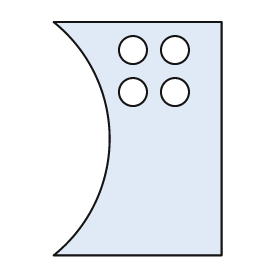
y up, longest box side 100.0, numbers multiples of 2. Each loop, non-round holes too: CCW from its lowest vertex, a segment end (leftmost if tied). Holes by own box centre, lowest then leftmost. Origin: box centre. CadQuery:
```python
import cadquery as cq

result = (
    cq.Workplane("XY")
    .moveTo(-36.0, -50.0)
    .lineTo(36.0, -50.0)
    .lineTo(36.0, 50.0)
    .lineTo(-36.0, 50.0)
    .threePointArc((-12.0, 0.0), (-36.0, -50.0))
    .close()
    .moveTo(-2.0, 20.0)
    .circle(6.0)
    .moveTo(16.0, 20.0)
    .circle(6.0)
    .moveTo(-2.0, 38.0)
    .circle(6.0)
    .moveTo(16.0, 38.0)
    .circle(6.0)
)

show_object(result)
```